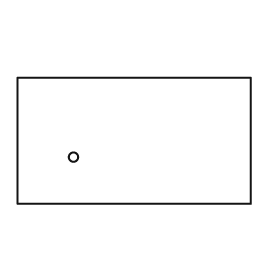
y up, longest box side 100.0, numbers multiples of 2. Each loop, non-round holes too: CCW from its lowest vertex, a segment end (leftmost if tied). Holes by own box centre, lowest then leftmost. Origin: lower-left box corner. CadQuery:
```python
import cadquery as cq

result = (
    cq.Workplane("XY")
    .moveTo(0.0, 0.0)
    .lineTo(100.0, 0.0)
    .lineTo(100.0, 54.0)
    .lineTo(0.0, 54.0)
    .close()
    .moveTo(24.0, 20.0)
    .circle(2.0)
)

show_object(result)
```